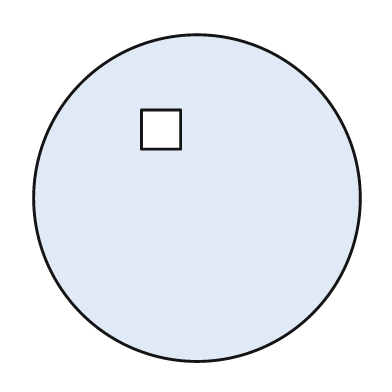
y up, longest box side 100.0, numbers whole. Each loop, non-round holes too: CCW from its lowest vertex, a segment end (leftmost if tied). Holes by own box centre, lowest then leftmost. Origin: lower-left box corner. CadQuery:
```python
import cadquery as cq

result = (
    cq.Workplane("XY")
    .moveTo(50.0, 50.0)
    .circle(50.0)
    .moveTo(33.0, 65.0)
    .lineTo(45.0, 65.0)
    .lineTo(45.0, 77.0)
    .lineTo(33.0, 77.0)
    .close()
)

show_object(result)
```